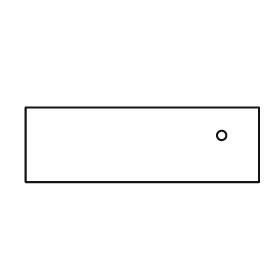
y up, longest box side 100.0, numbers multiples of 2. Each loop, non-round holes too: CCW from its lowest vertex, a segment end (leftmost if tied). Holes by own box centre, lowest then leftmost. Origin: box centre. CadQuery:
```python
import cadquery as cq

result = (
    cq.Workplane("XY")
    .moveTo(-50.0, -16.0)
    .lineTo(50.0, -16.0)
    .lineTo(50.0, 16.0)
    .lineTo(-50.0, 16.0)
    .close()
    .moveTo(34.0, 4.0)
    .circle(2.0)
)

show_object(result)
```